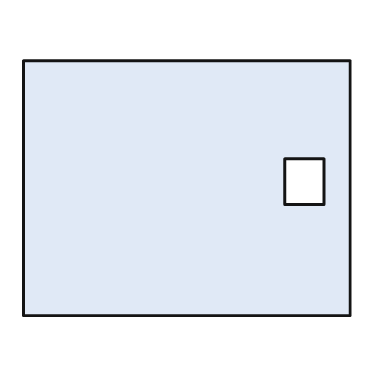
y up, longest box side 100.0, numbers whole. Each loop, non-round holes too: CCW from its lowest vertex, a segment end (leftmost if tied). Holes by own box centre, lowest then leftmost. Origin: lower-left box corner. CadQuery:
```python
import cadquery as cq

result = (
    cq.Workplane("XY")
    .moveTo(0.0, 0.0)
    .lineTo(100.0, 0.0)
    .lineTo(100.0, 78.0)
    .lineTo(0.0, 78.0)
    .close()
    .moveTo(80.0, 34.0)
    .lineTo(92.0, 34.0)
    .lineTo(92.0, 48.0)
    .lineTo(80.0, 48.0)
    .close()
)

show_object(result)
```